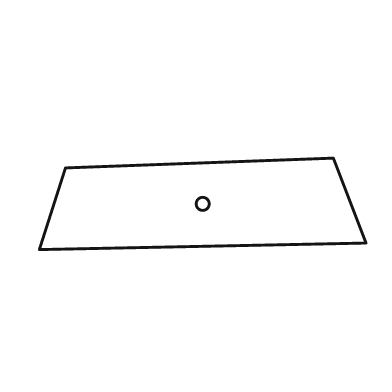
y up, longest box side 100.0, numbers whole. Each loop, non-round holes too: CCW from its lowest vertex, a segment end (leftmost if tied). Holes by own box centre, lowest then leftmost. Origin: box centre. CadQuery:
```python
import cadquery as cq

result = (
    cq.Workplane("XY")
    .moveTo(-50.0, -14.0)
    .lineTo(50.0, -12.0)
    .lineTo(40.0, 14.0)
    .lineTo(-42.0, 11.0)
    .close()
    .moveTo(0.0, 0.0)
    .circle(2.0)
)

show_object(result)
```